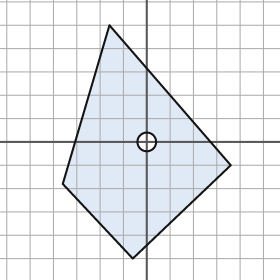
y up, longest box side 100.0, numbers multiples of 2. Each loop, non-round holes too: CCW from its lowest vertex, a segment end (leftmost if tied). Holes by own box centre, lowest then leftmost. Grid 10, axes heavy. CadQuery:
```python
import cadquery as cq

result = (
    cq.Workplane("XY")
    .moveTo(-6.0, -50.0)
    .lineTo(36.0, -10.0)
    .lineTo(-16.0, 50.0)
    .lineTo(-36.0, -18.0)
    .close()
    .moveTo(0.0, 0.0)
    .circle(4.0)
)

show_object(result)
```